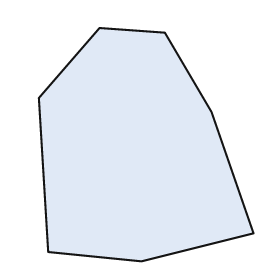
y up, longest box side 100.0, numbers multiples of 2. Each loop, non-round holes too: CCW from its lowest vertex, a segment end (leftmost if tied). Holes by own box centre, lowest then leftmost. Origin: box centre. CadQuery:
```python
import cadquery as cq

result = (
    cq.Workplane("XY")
    .moveTo(-2.0, -50.0)
    .lineTo(46.0, -38.0)
    .lineTo(28.0, 14.0)
    .lineTo(8.0, 48.0)
    .lineTo(-20.0, 50.0)
    .lineTo(-46.0, 20.0)
    .lineTo(-42.0, -46.0)
    .close()
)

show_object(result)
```